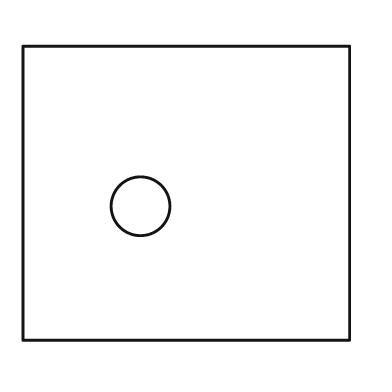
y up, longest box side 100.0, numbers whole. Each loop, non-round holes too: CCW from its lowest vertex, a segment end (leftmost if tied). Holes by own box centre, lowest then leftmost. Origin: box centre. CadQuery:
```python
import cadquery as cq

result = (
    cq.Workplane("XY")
    .moveTo(-50.0, -45.0)
    .lineTo(50.0, -45.0)
    .lineTo(50.0, 45.0)
    .lineTo(-50.0, 45.0)
    .close()
    .moveTo(-14.0, -4.0)
    .circle(9.0)
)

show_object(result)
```